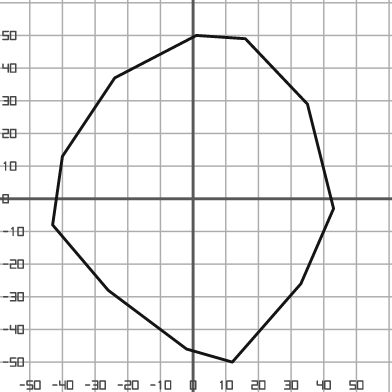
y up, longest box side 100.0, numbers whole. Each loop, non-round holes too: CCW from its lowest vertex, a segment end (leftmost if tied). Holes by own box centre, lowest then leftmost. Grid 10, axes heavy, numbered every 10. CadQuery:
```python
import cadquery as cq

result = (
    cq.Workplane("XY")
    .moveTo(12.0, -50.0)
    .lineTo(33.0, -26.0)
    .lineTo(43.0, -3.0)
    .lineTo(35.0, 29.0)
    .lineTo(16.0, 49.0)
    .lineTo(1.0, 50.0)
    .lineTo(-24.0, 37.0)
    .lineTo(-40.0, 13.0)
    .lineTo(-43.0, -8.0)
    .lineTo(-26.0, -28.0)
    .lineTo(-2.0, -46.0)
    .close()
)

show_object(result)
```